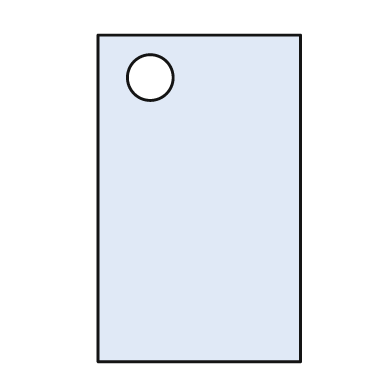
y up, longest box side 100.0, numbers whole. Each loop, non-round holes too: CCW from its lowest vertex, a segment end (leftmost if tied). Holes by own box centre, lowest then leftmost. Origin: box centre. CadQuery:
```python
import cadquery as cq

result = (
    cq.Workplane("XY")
    .moveTo(-31.0, -50.0)
    .lineTo(31.0, -50.0)
    .lineTo(31.0, 50.0)
    .lineTo(-31.0, 50.0)
    .close()
    .moveTo(-15.0, 37.0)
    .circle(7.0)
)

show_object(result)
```